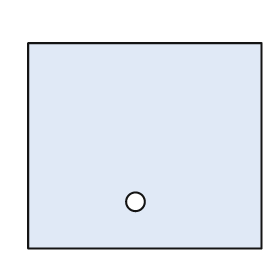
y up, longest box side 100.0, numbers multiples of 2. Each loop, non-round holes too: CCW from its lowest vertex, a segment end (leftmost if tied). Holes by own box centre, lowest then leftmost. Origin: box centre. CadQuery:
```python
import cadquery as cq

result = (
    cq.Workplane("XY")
    .moveTo(-50.0, -44.0)
    .lineTo(50.0, -44.0)
    .lineTo(50.0, 44.0)
    .lineTo(-50.0, 44.0)
    .close()
    .moveTo(-4.0, -24.0)
    .circle(4.0)
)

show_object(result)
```